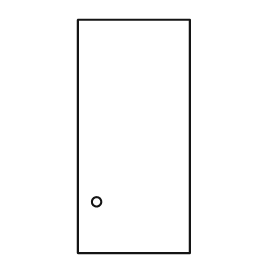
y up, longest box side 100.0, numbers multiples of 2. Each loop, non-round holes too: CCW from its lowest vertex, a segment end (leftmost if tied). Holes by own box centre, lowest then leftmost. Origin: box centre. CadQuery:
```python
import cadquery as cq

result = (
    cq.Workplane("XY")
    .moveTo(-24.0, -50.0)
    .lineTo(24.0, -50.0)
    .lineTo(24.0, 50.0)
    .lineTo(-24.0, 50.0)
    .close()
    .moveTo(-16.0, -28.0)
    .circle(2.0)
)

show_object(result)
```